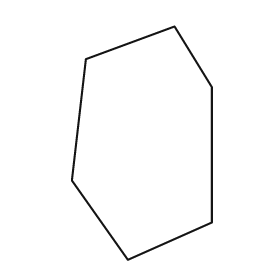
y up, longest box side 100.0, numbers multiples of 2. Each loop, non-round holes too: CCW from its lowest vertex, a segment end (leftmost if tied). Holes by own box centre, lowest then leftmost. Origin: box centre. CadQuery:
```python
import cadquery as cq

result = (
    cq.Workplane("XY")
    .moveTo(-6.0, -50.0)
    .lineTo(30.0, -34.0)
    .lineTo(30.0, 24.0)
    .lineTo(14.0, 50.0)
    .lineTo(-24.0, 36.0)
    .lineTo(-30.0, -16.0)
    .close()
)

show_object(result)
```